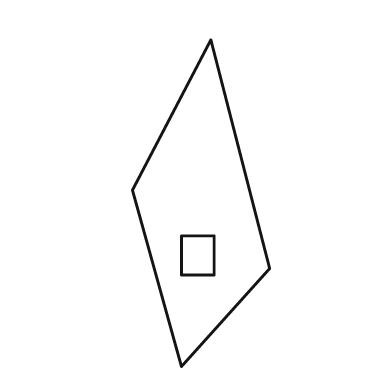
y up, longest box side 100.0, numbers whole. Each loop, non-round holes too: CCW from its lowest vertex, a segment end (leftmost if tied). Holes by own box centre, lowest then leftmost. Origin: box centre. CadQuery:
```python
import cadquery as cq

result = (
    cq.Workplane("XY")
    .moveTo(-6.0, -50.0)
    .lineTo(21.0, -20.0)
    .lineTo(3.0, 50.0)
    .lineTo(-21.0, 4.0)
    .close()
    .moveTo(-6.0, -22.0)
    .lineTo(4.0, -22.0)
    .lineTo(4.0, -10.0)
    .lineTo(-6.0, -10.0)
    .close()
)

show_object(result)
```